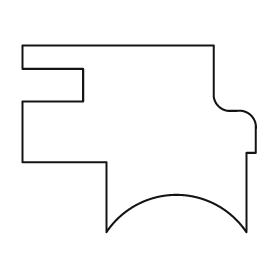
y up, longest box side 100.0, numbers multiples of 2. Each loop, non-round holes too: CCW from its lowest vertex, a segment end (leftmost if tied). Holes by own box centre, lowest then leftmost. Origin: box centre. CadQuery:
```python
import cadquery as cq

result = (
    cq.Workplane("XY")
    .moveTo(-14.0, -40.0)
    .threePointArc((16.0, -24.0), (46.0, -40.0))
    .lineTo(46.0, -6.0)
    .lineTo(50.0, -6.0)
    .lineTo(50.0, 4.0)
    .threePointArc((48.0, 10.0), (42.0, 12.0))
    .lineTo(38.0, 12.0)
    .threePointArc((34.0, 14.0), (32.0, 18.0))
    .lineTo(32.0, 40.0)
    .lineTo(-50.0, 40.0)
    .lineTo(-50.0, 30.0)
    .lineTo(-24.0, 30.0)
    .lineTo(-24.0, 16.0)
    .lineTo(-50.0, 16.0)
    .lineTo(-50.0, -10.0)
    .lineTo(-14.0, -10.0)
    .close()
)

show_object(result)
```